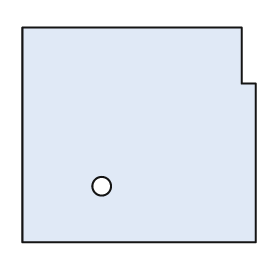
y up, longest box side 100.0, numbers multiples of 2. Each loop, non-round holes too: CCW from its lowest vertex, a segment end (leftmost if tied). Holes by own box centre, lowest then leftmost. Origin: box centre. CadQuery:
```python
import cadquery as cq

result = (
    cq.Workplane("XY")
    .moveTo(-50.0, -46.0)
    .lineTo(50.0, -46.0)
    .lineTo(50.0, 22.0)
    .lineTo(44.0, 22.0)
    .lineTo(44.0, 46.0)
    .lineTo(-50.0, 46.0)
    .close()
    .moveTo(-16.0, -22.0)
    .circle(4.0)
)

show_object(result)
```